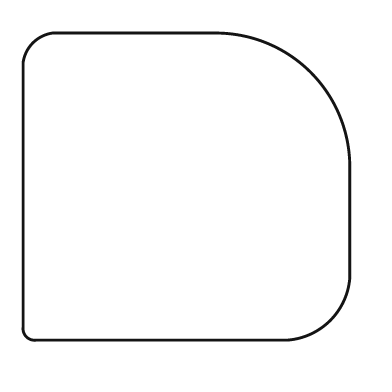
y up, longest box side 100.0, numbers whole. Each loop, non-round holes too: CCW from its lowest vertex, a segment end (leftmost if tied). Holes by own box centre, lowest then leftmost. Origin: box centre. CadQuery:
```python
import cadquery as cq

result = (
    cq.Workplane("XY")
    .moveTo(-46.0, -47.0)
    .lineTo(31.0, -47.0)
    .threePointArc((44.0, -41.0), (50.0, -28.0))
    .lineTo(50.0, 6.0)
    .threePointArc((38.0, 35.0), (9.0, 47.0))
    .lineTo(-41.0, 47.0)
    .threePointArc((-47.0, 44.0), (-50.0, 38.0))
    .lineTo(-50.0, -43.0)
    .threePointArc((-49.0, -46.0), (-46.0, -47.0))
    .close()
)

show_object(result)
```